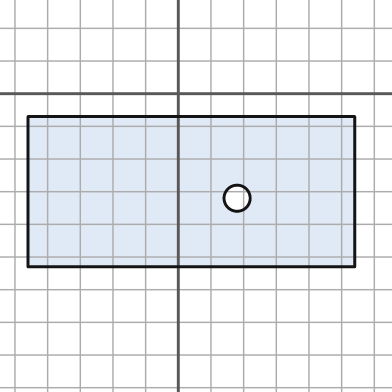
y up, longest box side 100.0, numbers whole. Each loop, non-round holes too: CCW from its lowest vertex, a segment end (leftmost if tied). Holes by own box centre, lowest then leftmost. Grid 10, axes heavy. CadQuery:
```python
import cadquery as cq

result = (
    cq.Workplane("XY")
    .moveTo(-46.0, -53.0)
    .lineTo(54.0, -53.0)
    .lineTo(54.0, -7.0)
    .lineTo(-46.0, -7.0)
    .close()
    .moveTo(18.0, -32.0)
    .circle(4.0)
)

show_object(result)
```